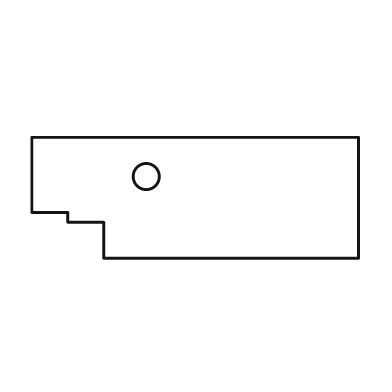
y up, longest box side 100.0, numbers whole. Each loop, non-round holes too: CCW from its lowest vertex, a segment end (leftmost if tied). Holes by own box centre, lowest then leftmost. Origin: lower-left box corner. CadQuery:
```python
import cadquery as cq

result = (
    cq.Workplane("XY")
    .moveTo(22.0, 0.0)
    .lineTo(100.0, 0.0)
    .lineTo(100.0, 37.0)
    .lineTo(0.0, 37.0)
    .lineTo(0.0, 14.0)
    .lineTo(11.0, 14.0)
    .lineTo(11.0, 11.0)
    .lineTo(22.0, 11.0)
    .close()
    .moveTo(35.0, 25.0)
    .circle(4.0)
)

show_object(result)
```